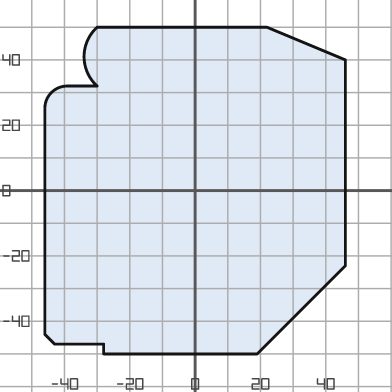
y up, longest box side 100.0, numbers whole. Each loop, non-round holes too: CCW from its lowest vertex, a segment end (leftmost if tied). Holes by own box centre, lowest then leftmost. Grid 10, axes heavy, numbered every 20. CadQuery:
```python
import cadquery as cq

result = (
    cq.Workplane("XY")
    .moveTo(-28.0, -50.0)
    .lineTo(19.0, -50.0)
    .lineTo(46.0, -23.0)
    .lineTo(46.0, 40.0)
    .lineTo(22.0, 50.0)
    .lineTo(-30.0, 50.0)
    .threePointArc((-34.0, 41.0), (-30.0, 32.0))
    .lineTo(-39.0, 32.0)
    .threePointArc((-44.0, 30.0), (-46.0, 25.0))
    .lineTo(-46.0, -44.0)
    .lineTo(-43.0, -47.0)
    .lineTo(-28.0, -47.0)
    .close()
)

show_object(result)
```